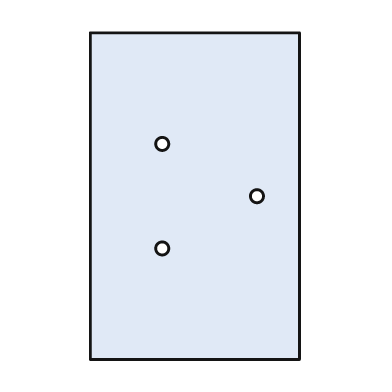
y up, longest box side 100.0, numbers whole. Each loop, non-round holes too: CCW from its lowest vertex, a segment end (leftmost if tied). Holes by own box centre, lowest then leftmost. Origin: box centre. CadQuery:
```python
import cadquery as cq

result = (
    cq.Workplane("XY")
    .moveTo(-32.0, -50.0)
    .lineTo(32.0, -50.0)
    .lineTo(32.0, 50.0)
    .lineTo(-32.0, 50.0)
    .close()
    .moveTo(-10.0, -16.0)
    .circle(2.0)
    .moveTo(19.0, 0.0)
    .circle(2.0)
    .moveTo(-10.0, 16.0)
    .circle(2.0)
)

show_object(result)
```